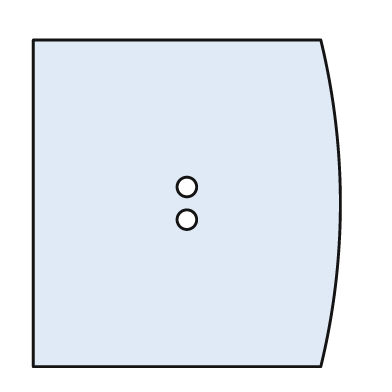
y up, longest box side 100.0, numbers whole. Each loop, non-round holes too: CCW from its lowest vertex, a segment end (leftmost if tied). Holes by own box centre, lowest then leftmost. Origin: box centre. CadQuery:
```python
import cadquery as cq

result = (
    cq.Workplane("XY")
    .moveTo(-47.0, -50.0)
    .lineTo(41.0, -50.0)
    .threePointArc((47.0, 0.0), (41.0, 50.0))
    .lineTo(-47.0, 50.0)
    .close()
    .moveTo(0.0, -5.0)
    .circle(3.0)
    .moveTo(0.0, 5.0)
    .circle(3.0)
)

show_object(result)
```